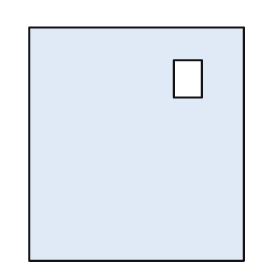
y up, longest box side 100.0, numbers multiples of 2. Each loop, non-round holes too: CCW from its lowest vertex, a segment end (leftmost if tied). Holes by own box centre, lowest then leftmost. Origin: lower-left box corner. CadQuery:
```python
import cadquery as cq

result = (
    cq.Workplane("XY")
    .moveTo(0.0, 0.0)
    .lineTo(92.0, 0.0)
    .lineTo(92.0, 100.0)
    .lineTo(0.0, 100.0)
    .close()
    .moveTo(62.0, 70.0)
    .lineTo(74.0, 70.0)
    .lineTo(74.0, 86.0)
    .lineTo(62.0, 86.0)
    .close()
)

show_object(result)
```